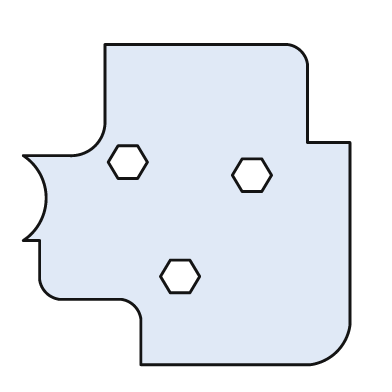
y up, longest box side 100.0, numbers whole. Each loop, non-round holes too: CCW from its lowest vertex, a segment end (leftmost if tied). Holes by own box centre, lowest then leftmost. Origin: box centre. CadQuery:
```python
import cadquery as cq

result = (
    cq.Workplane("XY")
    .moveTo(-14.0, -49.0)
    .lineTo(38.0, -49.0)
    .threePointArc((46.0, -45.0), (50.0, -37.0))
    .lineTo(50.0, 19.0)
    .lineTo(37.0, 19.0)
    .lineTo(37.0, 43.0)
    .threePointArc((35.0, 47.0), (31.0, 49.0))
    .lineTo(-25.0, 49.0)
    .lineTo(-25.0, 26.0)
    .threePointArc((-28.0, 18.0), (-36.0, 15.0))
    .lineTo(-50.0, 15.0)
    .threePointArc((-43.0, 2.0), (-50.0, -11.0))
    .lineTo(-45.0, -11.0)
    .lineTo(-45.0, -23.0)
    .threePointArc((-43.0, -27.0), (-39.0, -29.0))
    .lineTo(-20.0, -29.0)
    .threePointArc((-16.0, -31.0), (-14.0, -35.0))
    .close()
    .moveTo(-5.0, -27.0)
    .lineTo(1.0, -27.0)
    .lineTo(4.0, -22.0)
    .lineTo(1.0, -17.0)
    .lineTo(-5.0, -17.0)
    .lineTo(-8.0, -22.0)
    .close()
    .moveTo(17.0, 4.0)
    .lineTo(23.0, 4.0)
    .lineTo(26.0, 9.0)
    .lineTo(23.0, 14.0)
    .lineTo(17.0, 14.0)
    .lineTo(14.0, 9.0)
    .close()
    .moveTo(-21.0, 8.0)
    .lineTo(-15.0, 8.0)
    .lineTo(-12.0, 13.0)
    .lineTo(-15.0, 18.0)
    .lineTo(-21.0, 18.0)
    .lineTo(-24.0, 13.0)
    .close()
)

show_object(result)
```